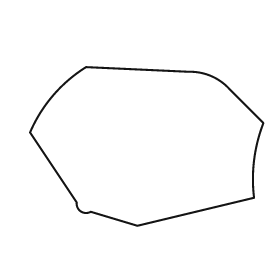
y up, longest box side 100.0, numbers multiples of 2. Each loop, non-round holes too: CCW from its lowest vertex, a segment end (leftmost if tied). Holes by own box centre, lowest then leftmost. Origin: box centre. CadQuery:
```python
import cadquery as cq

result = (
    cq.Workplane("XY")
    .moveTo(-4.0, -34.0)
    .lineTo(46.0, -22.0)
    .threePointArc((46.0, -6.0), (50.0, 10.0))
    .lineTo(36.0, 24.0)
    .threePointArc((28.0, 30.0), (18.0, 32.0))
    .lineTo(-26.0, 34.0)
    .threePointArc((-40.0, 22.0), (-50.0, 6.0))
    .lineTo(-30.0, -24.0)
    .threePointArc((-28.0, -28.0), (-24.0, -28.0))
    .close()
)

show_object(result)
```